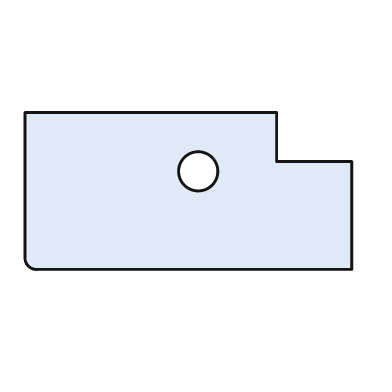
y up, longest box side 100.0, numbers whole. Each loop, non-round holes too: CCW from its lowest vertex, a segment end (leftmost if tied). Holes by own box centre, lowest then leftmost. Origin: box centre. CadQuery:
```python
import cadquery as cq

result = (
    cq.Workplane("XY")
    .moveTo(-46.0, -24.0)
    .lineTo(50.0, -24.0)
    .lineTo(50.0, 9.0)
    .lineTo(27.0, 9.0)
    .lineTo(27.0, 24.0)
    .lineTo(-50.0, 24.0)
    .lineTo(-50.0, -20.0)
    .threePointArc((-49.0, -23.0), (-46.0, -24.0))
    .close()
    .moveTo(3.0, 6.0)
    .circle(6.0)
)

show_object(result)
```